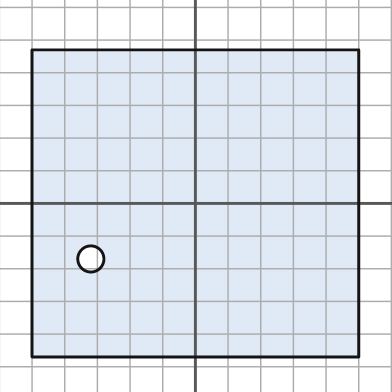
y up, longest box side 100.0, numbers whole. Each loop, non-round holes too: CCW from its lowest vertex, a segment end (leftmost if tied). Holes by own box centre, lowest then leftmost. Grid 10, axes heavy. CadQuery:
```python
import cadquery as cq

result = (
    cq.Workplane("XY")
    .moveTo(-50.0, -47.0)
    .lineTo(50.0, -47.0)
    .lineTo(50.0, 47.0)
    .lineTo(-50.0, 47.0)
    .close()
    .moveTo(-32.0, -17.0)
    .circle(4.0)
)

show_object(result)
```